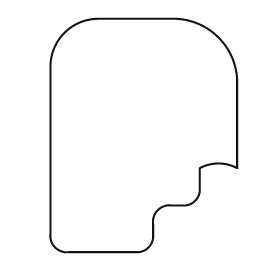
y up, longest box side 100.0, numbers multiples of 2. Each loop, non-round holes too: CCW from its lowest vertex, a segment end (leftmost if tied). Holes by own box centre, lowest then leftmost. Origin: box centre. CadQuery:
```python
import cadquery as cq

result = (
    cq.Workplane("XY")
    .moveTo(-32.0, -50.0)
    .lineTo(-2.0, -50.0)
    .threePointArc((2.0, -48.0), (4.0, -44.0))
    .lineTo(4.0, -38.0)
    .threePointArc((6.0, -32.0), (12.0, -30.0))
    .lineTo(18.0, -30.0)
    .threePointArc((22.0, -28.0), (24.0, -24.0))
    .lineTo(24.0, -14.0)
    .threePointArc((32.0, -12.0), (40.0, -14.0))
    .lineTo(40.0, 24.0)
    .threePointArc((32.0, 42.0), (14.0, 50.0))
    .lineTo(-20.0, 50.0)
    .threePointArc((-34.0, 44.0), (-40.0, 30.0))
    .lineTo(-40.0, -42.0)
    .threePointArc((-38.0, -48.0), (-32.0, -50.0))
    .close()
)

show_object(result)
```